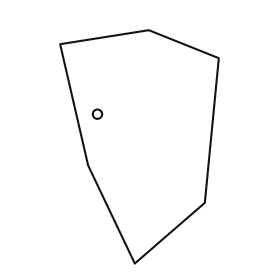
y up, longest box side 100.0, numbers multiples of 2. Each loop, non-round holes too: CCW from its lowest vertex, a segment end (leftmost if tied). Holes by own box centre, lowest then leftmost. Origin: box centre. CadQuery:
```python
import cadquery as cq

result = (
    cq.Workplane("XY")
    .moveTo(-2.0, -50.0)
    .lineTo(28.0, -24.0)
    .lineTo(34.0, 38.0)
    .lineTo(4.0, 50.0)
    .lineTo(-34.0, 44.0)
    .lineTo(-22.0, -8.0)
    .close()
    .moveTo(-18.0, 14.0)
    .circle(2.0)
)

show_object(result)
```